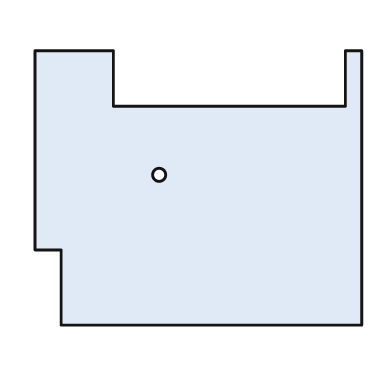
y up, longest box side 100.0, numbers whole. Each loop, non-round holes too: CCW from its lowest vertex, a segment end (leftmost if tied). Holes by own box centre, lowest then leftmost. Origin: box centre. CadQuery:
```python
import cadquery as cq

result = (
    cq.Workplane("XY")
    .moveTo(-42.0, -42.0)
    .lineTo(50.0, -42.0)
    .lineTo(50.0, 42.0)
    .lineTo(45.0, 42.0)
    .lineTo(45.0, 25.0)
    .lineTo(-26.0, 25.0)
    .lineTo(-26.0, 42.0)
    .lineTo(-50.0, 42.0)
    .lineTo(-50.0, -19.0)
    .lineTo(-42.0, -19.0)
    .close()
    .moveTo(-12.0, 4.0)
    .circle(2.0)
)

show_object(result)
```